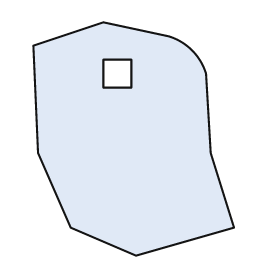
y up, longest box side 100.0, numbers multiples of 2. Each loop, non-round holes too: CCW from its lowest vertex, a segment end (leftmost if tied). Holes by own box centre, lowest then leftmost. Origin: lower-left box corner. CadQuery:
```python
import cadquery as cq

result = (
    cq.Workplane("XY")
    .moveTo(44.0, 0.0)
    .lineTo(86.0, 12.0)
    .lineTo(76.0, 44.0)
    .lineTo(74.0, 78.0)
    .threePointArc((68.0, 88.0), (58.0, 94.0))
    .lineTo(30.0, 100.0)
    .lineTo(0.0, 90.0)
    .lineTo(2.0, 44.0)
    .lineTo(16.0, 12.0)
    .close()
    .moveTo(30.0, 72.0)
    .lineTo(42.0, 72.0)
    .lineTo(42.0, 84.0)
    .lineTo(30.0, 84.0)
    .close()
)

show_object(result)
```